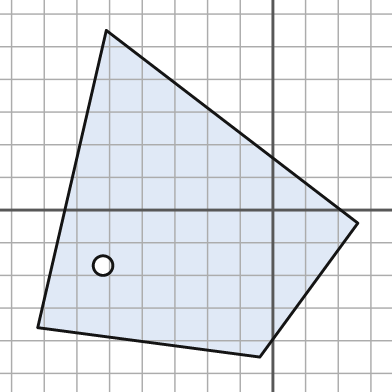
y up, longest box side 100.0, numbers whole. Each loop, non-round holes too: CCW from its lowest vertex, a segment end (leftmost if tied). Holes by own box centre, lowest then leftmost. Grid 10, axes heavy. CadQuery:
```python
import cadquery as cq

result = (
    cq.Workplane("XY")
    .moveTo(-4.0, -45.0)
    .lineTo(26.0, -4.0)
    .lineTo(-51.0, 55.0)
    .lineTo(-72.0, -36.0)
    .close()
    .moveTo(-52.0, -17.0)
    .circle(3.0)
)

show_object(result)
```